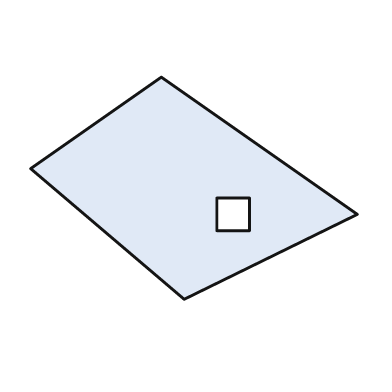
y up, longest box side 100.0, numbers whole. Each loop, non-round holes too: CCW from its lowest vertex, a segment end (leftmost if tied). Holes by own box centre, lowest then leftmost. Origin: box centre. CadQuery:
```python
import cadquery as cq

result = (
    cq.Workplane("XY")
    .moveTo(-3.0, -34.0)
    .lineTo(50.0, -8.0)
    .lineTo(-10.0, 34.0)
    .lineTo(-50.0, 6.0)
    .close()
    .moveTo(7.0, -13.0)
    .lineTo(17.0, -13.0)
    .lineTo(17.0, -3.0)
    .lineTo(7.0, -3.0)
    .close()
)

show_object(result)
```